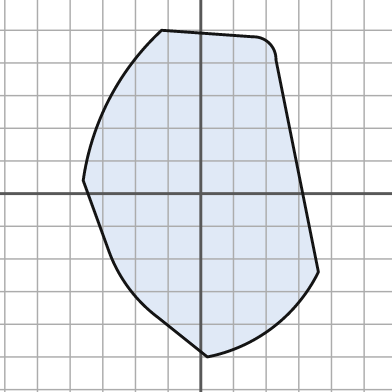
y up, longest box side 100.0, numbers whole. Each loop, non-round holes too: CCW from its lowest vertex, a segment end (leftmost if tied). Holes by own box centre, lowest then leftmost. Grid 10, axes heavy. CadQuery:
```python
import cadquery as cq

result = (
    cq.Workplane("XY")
    .moveTo(2.0, -50.0)
    .threePointArc((22.0, -41.0), (36.0, -24.0))
    .lineTo(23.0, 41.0)
    .threePointArc((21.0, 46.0), (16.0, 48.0))
    .lineTo(-12.0, 50.0)
    .threePointArc((-28.0, 29.0), (-36.0, 4.0))
    .lineTo(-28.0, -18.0)
    .threePointArc((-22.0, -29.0), (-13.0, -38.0))
    .close()
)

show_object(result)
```